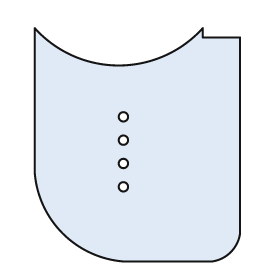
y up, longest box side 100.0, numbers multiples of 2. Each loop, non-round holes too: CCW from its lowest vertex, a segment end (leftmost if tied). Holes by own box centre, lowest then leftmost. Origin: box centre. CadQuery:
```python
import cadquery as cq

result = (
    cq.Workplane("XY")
    .moveTo(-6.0, -50.0)
    .lineTo(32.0, -50.0)
    .threePointArc((40.0, -46.0), (44.0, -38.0))
    .lineTo(44.0, 46.0)
    .lineTo(28.0, 46.0)
    .lineTo(28.0, 50.0)
    .threePointArc((-8.0, 34.0), (-44.0, 50.0))
    .lineTo(-44.0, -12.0)
    .threePointArc((-32.0, -38.0), (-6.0, -50.0))
    .close()
    .moveTo(-6.0, -18.0)
    .circle(2.0)
    .moveTo(-6.0, -8.0)
    .circle(2.0)
    .moveTo(-6.0, 2.0)
    .circle(2.0)
    .moveTo(-6.0, 12.0)
    .circle(2.0)
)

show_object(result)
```